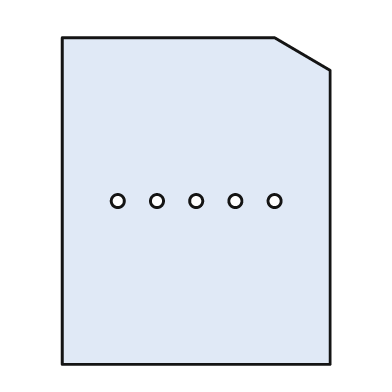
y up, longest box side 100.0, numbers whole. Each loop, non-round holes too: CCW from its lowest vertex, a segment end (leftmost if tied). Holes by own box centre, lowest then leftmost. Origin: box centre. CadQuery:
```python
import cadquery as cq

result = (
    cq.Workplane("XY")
    .moveTo(-41.0, -50.0)
    .lineTo(41.0, -50.0)
    .lineTo(41.0, 40.0)
    .lineTo(24.0, 50.0)
    .lineTo(-41.0, 50.0)
    .close()
    .moveTo(-24.0, 0.0)
    .circle(2.0)
    .moveTo(-12.0, 0.0)
    .circle(2.0)
    .moveTo(0.0, 0.0)
    .circle(2.0)
    .moveTo(12.0, 0.0)
    .circle(2.0)
    .moveTo(24.0, 0.0)
    .circle(2.0)
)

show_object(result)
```